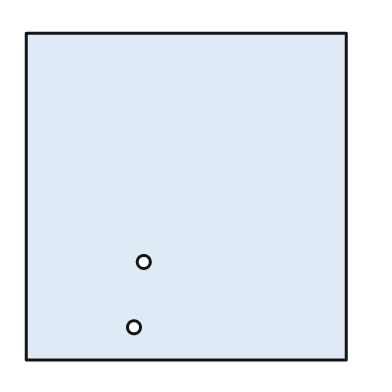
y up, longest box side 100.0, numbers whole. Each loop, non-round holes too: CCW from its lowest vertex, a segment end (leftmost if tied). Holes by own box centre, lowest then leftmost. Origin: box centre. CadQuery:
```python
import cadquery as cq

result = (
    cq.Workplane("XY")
    .moveTo(-49.0, -50.0)
    .lineTo(49.0, -50.0)
    .lineTo(49.0, 50.0)
    .lineTo(-49.0, 50.0)
    .close()
    .moveTo(-16.0, -40.0)
    .circle(2.0)
    .moveTo(-13.0, -20.0)
    .circle(2.0)
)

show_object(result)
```